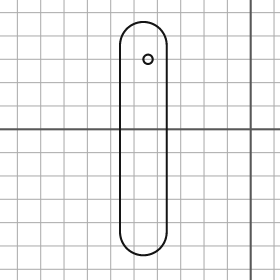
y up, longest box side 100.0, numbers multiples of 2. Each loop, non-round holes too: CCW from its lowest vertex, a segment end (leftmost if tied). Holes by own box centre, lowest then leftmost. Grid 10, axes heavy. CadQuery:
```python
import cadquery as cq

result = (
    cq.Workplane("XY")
    .moveTo(-56.0, -44.0)
    .threePointArc((-46.0, -54.0), (-36.0, -44.0))
    .lineTo(-36.0, 36.0)
    .threePointArc((-46.0, 46.0), (-56.0, 36.0))
    .close()
    .moveTo(-44.0, 30.0)
    .circle(2.0)
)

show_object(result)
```